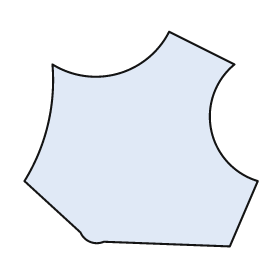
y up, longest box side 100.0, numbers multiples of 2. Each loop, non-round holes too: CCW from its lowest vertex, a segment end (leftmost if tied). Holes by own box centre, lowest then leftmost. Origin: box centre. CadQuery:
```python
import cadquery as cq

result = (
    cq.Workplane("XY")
    .moveTo(38.0, -46.0)
    .lineTo(50.0, -18.0)
    .threePointArc((30.0, 4.0), (40.0, 32.0))
    .lineTo(12.0, 46.0)
    .threePointArc((-10.0, 28.0), (-38.0, 32.0))
    .threePointArc((-40.0, 6.0), (-50.0, -18.0))
    .lineTo(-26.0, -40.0)
    .threePointArc((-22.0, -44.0), (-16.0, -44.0))
    .close()
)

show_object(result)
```